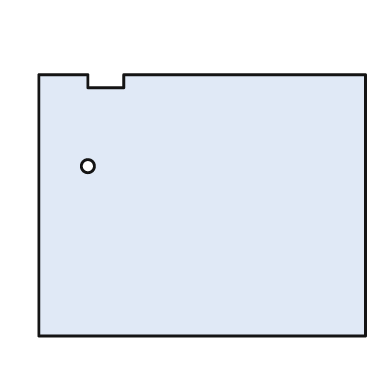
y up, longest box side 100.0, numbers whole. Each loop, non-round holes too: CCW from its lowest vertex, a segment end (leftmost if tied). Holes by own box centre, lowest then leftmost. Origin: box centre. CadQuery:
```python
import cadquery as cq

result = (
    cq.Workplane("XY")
    .moveTo(-50.0, -40.0)
    .lineTo(50.0, -40.0)
    .lineTo(50.0, 40.0)
    .lineTo(-24.0, 40.0)
    .lineTo(-24.0, 36.0)
    .lineTo(-35.0, 36.0)
    .lineTo(-35.0, 40.0)
    .lineTo(-50.0, 40.0)
    .close()
    .moveTo(-35.0, 12.0)
    .circle(2.0)
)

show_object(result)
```